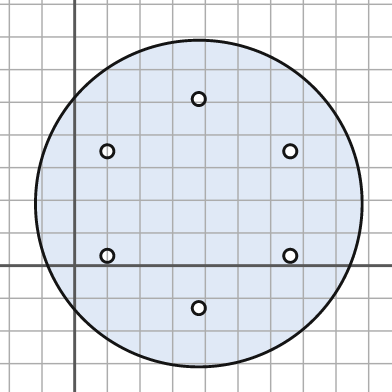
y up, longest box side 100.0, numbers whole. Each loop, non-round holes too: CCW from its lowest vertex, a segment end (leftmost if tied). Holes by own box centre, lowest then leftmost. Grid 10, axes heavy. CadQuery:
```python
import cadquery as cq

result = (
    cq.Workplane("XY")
    .moveTo(38.0, 19.0)
    .circle(50.0)
    .moveTo(38.0, -13.0)
    .circle(2.0)
    .moveTo(10.0, 3.0)
    .circle(2.0)
    .moveTo(66.0, 3.0)
    .circle(2.0)
    .moveTo(10.0, 35.0)
    .circle(2.0)
    .moveTo(66.0, 35.0)
    .circle(2.0)
    .moveTo(38.0, 51.0)
    .circle(2.0)
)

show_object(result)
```